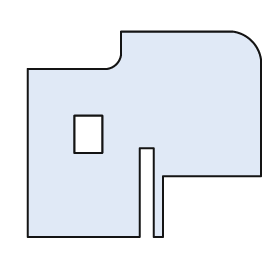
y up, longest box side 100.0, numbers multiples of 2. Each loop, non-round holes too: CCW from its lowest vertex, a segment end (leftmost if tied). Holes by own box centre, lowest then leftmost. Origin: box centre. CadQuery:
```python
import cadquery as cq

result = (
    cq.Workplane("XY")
    .moveTo(-50.0, -44.0)
    .lineTo(-2.0, -44.0)
    .lineTo(-2.0, -6.0)
    .lineTo(4.0, -6.0)
    .lineTo(4.0, -44.0)
    .lineTo(8.0, -44.0)
    .lineTo(8.0, -18.0)
    .lineTo(50.0, -18.0)
    .lineTo(50.0, 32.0)
    .threePointArc((46.0, 40.0), (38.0, 44.0))
    .lineTo(-10.0, 44.0)
    .lineTo(-10.0, 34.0)
    .threePointArc((-12.0, 30.0), (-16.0, 28.0))
    .lineTo(-50.0, 28.0)
    .close()
    .moveTo(-30.0, -8.0)
    .lineTo(-18.0, -8.0)
    .lineTo(-18.0, 8.0)
    .lineTo(-30.0, 8.0)
    .close()
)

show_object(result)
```